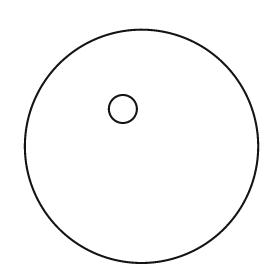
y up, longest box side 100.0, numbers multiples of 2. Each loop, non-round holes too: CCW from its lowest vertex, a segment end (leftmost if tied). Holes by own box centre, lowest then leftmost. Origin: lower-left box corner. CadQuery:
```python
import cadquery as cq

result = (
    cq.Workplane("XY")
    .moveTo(50.0, 50.0)
    .circle(50.0)
    .moveTo(42.0, 66.0)
    .circle(6.0)
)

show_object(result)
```